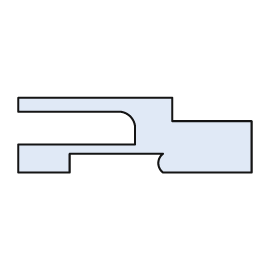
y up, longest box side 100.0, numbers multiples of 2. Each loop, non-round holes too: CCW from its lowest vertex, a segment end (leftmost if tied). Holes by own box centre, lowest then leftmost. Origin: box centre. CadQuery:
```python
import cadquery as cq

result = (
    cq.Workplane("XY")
    .moveTo(-50.0, -16.0)
    .lineTo(-28.0, -16.0)
    .lineTo(-28.0, -8.0)
    .lineTo(12.0, -8.0)
    .threePointArc((10.0, -12.0), (12.0, -16.0))
    .lineTo(50.0, -16.0)
    .lineTo(50.0, 6.0)
    .lineTo(16.0, 6.0)
    .lineTo(16.0, 16.0)
    .lineTo(-50.0, 16.0)
    .lineTo(-50.0, 10.0)
    .lineTo(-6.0, 10.0)
    .threePointArc((-2.0, 8.0), (0.0, 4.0))
    .lineTo(0.0, -4.0)
    .lineTo(-50.0, -4.0)
    .close()
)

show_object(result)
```